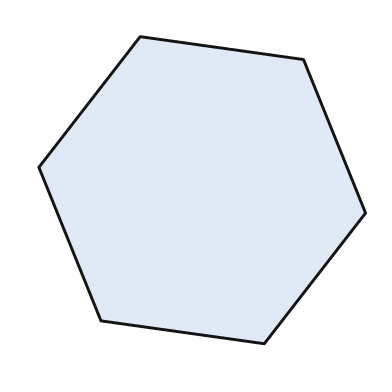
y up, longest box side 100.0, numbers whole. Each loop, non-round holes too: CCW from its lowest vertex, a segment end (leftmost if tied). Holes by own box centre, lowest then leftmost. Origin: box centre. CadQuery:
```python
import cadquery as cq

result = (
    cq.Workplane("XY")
    .moveTo(19.0, -47.0)
    .lineTo(50.0, -7.0)
    .lineTo(31.0, 40.0)
    .lineTo(-19.0, 47.0)
    .lineTo(-50.0, 7.0)
    .lineTo(-31.0, -40.0)
    .close()
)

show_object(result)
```